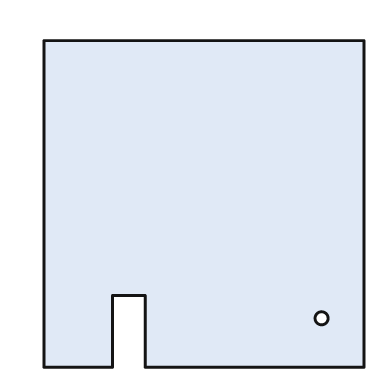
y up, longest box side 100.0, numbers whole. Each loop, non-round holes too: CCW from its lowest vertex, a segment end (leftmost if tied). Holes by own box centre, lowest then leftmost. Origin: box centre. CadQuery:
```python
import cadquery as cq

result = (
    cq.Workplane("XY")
    .moveTo(-49.0, -50.0)
    .lineTo(-28.0, -50.0)
    .lineTo(-28.0, -28.0)
    .lineTo(-18.0, -28.0)
    .lineTo(-18.0, -50.0)
    .lineTo(49.0, -50.0)
    .lineTo(49.0, 50.0)
    .lineTo(-49.0, 50.0)
    .close()
    .moveTo(36.0, -35.0)
    .circle(2.0)
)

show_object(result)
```